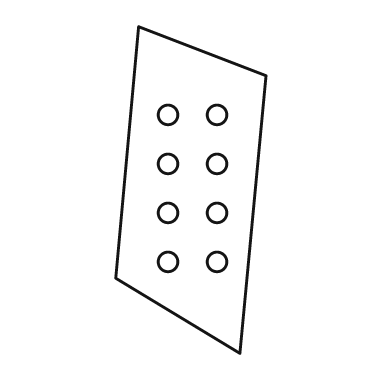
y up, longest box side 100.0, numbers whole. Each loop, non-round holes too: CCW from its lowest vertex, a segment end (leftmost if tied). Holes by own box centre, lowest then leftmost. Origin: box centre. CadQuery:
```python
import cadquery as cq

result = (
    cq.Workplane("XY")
    .moveTo(15.0, -50.0)
    .lineTo(23.0, 35.0)
    .lineTo(-16.0, 50.0)
    .lineTo(-23.0, -27.0)
    .close()
    .moveTo(-7.0, -22.0)
    .circle(3.0)
    .moveTo(8.0, -22.0)
    .circle(3.0)
    .moveTo(-7.0, -7.0)
    .circle(3.0)
    .moveTo(8.0, -7.0)
    .circle(3.0)
    .moveTo(-7.0, 8.0)
    .circle(3.0)
    .moveTo(8.0, 8.0)
    .circle(3.0)
    .moveTo(-7.0, 23.0)
    .circle(3.0)
    .moveTo(8.0, 23.0)
    .circle(3.0)
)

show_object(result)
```